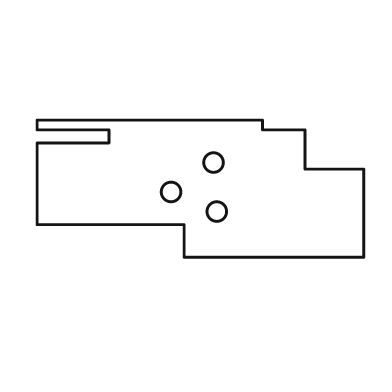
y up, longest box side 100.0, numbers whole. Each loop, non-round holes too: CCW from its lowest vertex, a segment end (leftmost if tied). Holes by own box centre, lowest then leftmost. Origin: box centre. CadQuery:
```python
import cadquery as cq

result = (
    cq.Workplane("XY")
    .moveTo(-5.0, -21.0)
    .lineTo(50.0, -21.0)
    .lineTo(50.0, 6.0)
    .lineTo(32.0, 6.0)
    .lineTo(32.0, 18.0)
    .lineTo(19.0, 18.0)
    .lineTo(19.0, 21.0)
    .lineTo(-50.0, 21.0)
    .lineTo(-50.0, 18.0)
    .lineTo(-28.0, 18.0)
    .lineTo(-28.0, 14.0)
    .lineTo(-50.0, 14.0)
    .lineTo(-50.0, -11.0)
    .lineTo(-5.0, -11.0)
    .close()
    .moveTo(5.0, -7.0)
    .circle(3.0)
    .moveTo(-9.0, -1.0)
    .circle(3.0)
    .moveTo(4.0, 8.0)
    .circle(3.0)
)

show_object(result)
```